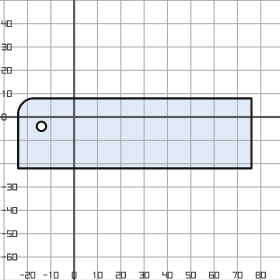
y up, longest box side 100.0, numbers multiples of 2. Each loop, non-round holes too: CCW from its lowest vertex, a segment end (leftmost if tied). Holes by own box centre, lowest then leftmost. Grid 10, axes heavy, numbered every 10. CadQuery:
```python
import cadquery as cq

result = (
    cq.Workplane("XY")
    .moveTo(-24.0, -22.0)
    .lineTo(76.0, -22.0)
    .lineTo(76.0, 8.0)
    .lineTo(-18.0, 8.0)
    .threePointArc((-22.0, 6.0), (-24.0, 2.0))
    .close()
    .moveTo(-14.0, -4.0)
    .circle(2.0)
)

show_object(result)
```